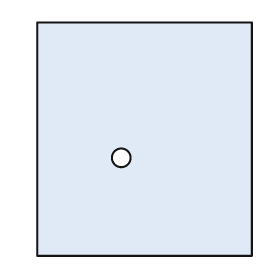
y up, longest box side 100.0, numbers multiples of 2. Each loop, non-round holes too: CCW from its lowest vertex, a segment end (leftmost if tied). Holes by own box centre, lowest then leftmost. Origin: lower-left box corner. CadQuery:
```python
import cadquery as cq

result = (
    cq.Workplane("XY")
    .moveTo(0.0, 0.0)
    .lineTo(92.0, 0.0)
    .lineTo(92.0, 100.0)
    .lineTo(0.0, 100.0)
    .close()
    .moveTo(36.0, 42.0)
    .circle(4.0)
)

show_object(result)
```